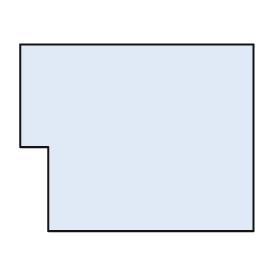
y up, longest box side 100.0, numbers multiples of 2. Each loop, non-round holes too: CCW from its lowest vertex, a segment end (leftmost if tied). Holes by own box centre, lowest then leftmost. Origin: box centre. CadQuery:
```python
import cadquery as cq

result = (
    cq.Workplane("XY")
    .moveTo(-38.0, -40.0)
    .lineTo(50.0, -40.0)
    .lineTo(50.0, 40.0)
    .lineTo(-50.0, 40.0)
    .lineTo(-50.0, -4.0)
    .lineTo(-38.0, -4.0)
    .close()
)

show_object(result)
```